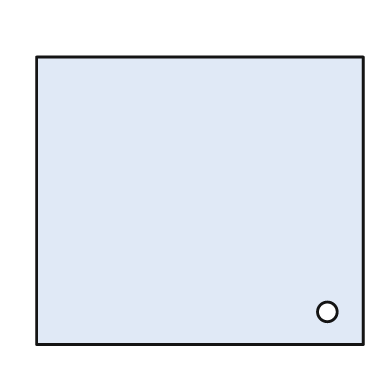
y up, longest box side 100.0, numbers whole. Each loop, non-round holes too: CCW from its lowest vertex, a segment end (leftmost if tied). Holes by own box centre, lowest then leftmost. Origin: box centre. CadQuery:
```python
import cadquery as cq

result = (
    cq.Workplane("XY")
    .moveTo(-50.0, -44.0)
    .lineTo(50.0, -44.0)
    .lineTo(50.0, 44.0)
    .lineTo(-50.0, 44.0)
    .close()
    .moveTo(39.0, -34.0)
    .circle(3.0)
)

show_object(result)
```